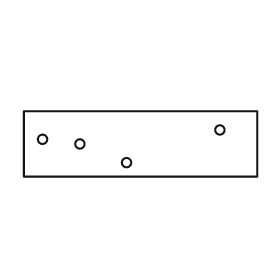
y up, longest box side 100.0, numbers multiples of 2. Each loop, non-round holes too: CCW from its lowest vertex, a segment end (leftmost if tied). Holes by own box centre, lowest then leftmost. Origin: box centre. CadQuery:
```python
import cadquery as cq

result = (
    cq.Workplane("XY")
    .moveTo(-50.0, -14.0)
    .lineTo(50.0, -14.0)
    .lineTo(50.0, 14.0)
    .lineTo(-50.0, 14.0)
    .close()
    .moveTo(-6.0, -8.0)
    .circle(2.0)
    .moveTo(-26.0, 0.0)
    .circle(2.0)
    .moveTo(-42.0, 2.0)
    .circle(2.0)
    .moveTo(34.0, 6.0)
    .circle(2.0)
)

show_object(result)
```